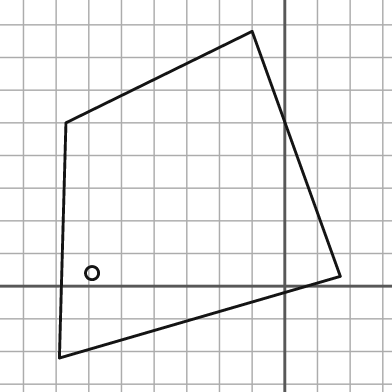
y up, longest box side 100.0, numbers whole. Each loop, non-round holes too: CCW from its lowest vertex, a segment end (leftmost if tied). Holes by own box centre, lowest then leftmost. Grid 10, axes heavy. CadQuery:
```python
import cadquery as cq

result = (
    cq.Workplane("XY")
    .moveTo(-69.0, -22.0)
    .lineTo(17.0, 3.0)
    .lineTo(-10.0, 78.0)
    .lineTo(-67.0, 50.0)
    .close()
    .moveTo(-59.0, 4.0)
    .circle(2.0)
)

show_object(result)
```